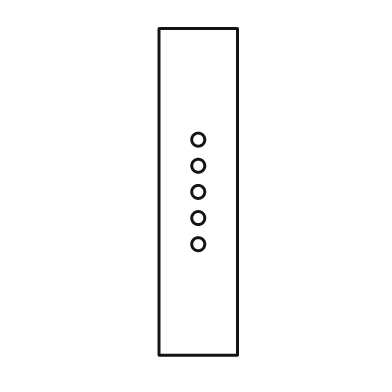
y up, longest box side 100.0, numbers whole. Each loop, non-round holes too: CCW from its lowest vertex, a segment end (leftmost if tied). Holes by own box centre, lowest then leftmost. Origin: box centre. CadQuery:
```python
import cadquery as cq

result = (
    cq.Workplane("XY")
    .moveTo(-12.0, -50.0)
    .lineTo(12.0, -50.0)
    .lineTo(12.0, 50.0)
    .lineTo(-12.0, 50.0)
    .close()
    .moveTo(0.0, -16.0)
    .circle(2.0)
    .moveTo(0.0, -8.0)
    .circle(2.0)
    .moveTo(0.0, 0.0)
    .circle(2.0)
    .moveTo(0.0, 8.0)
    .circle(2.0)
    .moveTo(0.0, 16.0)
    .circle(2.0)
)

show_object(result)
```